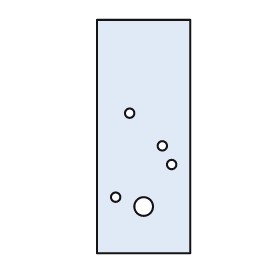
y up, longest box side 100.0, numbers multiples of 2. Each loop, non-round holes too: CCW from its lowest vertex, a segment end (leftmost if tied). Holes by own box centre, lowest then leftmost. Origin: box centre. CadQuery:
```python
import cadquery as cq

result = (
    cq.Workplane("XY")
    .moveTo(-20.0, -50.0)
    .lineTo(20.0, -50.0)
    .lineTo(20.0, 50.0)
    .lineTo(-20.0, 50.0)
    .close()
    .moveTo(0.0, -30.0)
    .circle(4.0)
    .moveTo(-12.0, -26.0)
    .circle(2.0)
    .moveTo(12.0, -12.0)
    .circle(2.0)
    .moveTo(8.0, -4.0)
    .circle(2.0)
    .moveTo(-6.0, 10.0)
    .circle(2.0)
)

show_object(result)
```